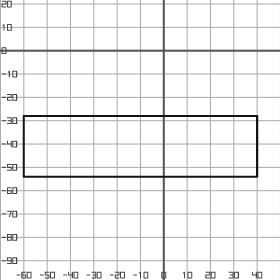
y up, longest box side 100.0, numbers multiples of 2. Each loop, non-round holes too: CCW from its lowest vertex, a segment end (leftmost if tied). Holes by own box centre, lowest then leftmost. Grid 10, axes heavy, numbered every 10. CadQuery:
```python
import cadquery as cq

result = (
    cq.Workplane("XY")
    .moveTo(-60.0, -54.0)
    .lineTo(40.0, -54.0)
    .lineTo(40.0, -28.0)
    .lineTo(-60.0, -28.0)
    .close()
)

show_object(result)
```